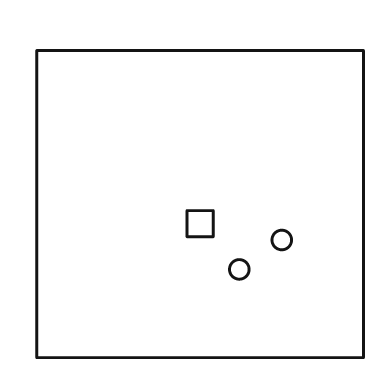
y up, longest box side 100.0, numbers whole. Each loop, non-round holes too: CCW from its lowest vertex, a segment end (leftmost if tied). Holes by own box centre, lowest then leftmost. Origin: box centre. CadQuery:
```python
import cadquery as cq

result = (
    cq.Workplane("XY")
    .moveTo(-50.0, -47.0)
    .lineTo(50.0, -47.0)
    .lineTo(50.0, 47.0)
    .lineTo(-50.0, 47.0)
    .close()
    .moveTo(12.0, -20.0)
    .circle(3.0)
    .moveTo(25.0, -11.0)
    .circle(3.0)
    .moveTo(-4.0, -10.0)
    .lineTo(4.0, -10.0)
    .lineTo(4.0, -2.0)
    .lineTo(-4.0, -2.0)
    .close()
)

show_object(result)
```